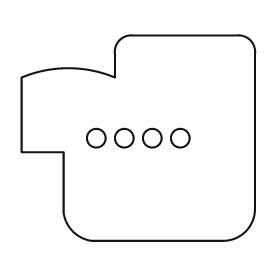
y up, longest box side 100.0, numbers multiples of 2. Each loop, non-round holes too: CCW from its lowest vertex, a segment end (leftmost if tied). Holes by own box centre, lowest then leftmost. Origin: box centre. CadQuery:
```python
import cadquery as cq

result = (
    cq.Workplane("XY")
    .moveTo(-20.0, -44.0)
    .lineTo(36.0, -44.0)
    .threePointArc((46.0, -40.0), (50.0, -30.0))
    .lineTo(50.0, 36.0)
    .threePointArc((48.0, 42.0), (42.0, 44.0))
    .lineTo(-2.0, 44.0)
    .threePointArc((-8.0, 42.0), (-10.0, 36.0))
    .lineTo(-10.0, 26.0)
    .threePointArc((-30.0, 30.0), (-50.0, 26.0))
    .lineTo(-50.0, -6.0)
    .lineTo(-32.0, -6.0)
    .lineTo(-32.0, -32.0)
    .threePointArc((-28.0, -40.0), (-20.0, -44.0))
    .close()
    .moveTo(-18.0, 0.0)
    .circle(4.0)
    .moveTo(-6.0, 0.0)
    .circle(4.0)
    .moveTo(6.0, 0.0)
    .circle(4.0)
    .moveTo(18.0, 0.0)
    .circle(4.0)
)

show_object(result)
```